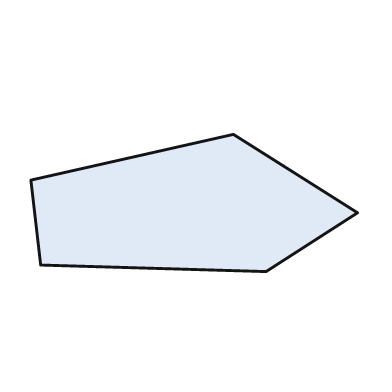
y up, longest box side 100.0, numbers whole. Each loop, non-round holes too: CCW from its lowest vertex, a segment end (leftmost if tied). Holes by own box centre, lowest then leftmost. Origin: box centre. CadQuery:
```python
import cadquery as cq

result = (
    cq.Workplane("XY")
    .moveTo(22.0, -21.0)
    .lineTo(50.0, -3.0)
    .lineTo(12.0, 21.0)
    .lineTo(-50.0, 7.0)
    .lineTo(-47.0, -19.0)
    .close()
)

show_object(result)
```